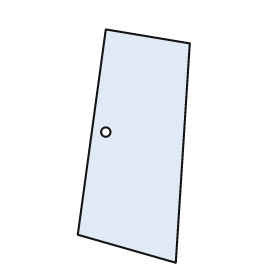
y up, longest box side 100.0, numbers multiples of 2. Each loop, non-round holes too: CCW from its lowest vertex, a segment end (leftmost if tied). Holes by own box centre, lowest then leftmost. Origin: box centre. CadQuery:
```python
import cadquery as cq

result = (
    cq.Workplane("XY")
    .moveTo(18.0, -50.0)
    .lineTo(24.0, 44.0)
    .lineTo(-12.0, 50.0)
    .lineTo(-24.0, -38.0)
    .close()
    .moveTo(-12.0, 6.0)
    .circle(2.0)
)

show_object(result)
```